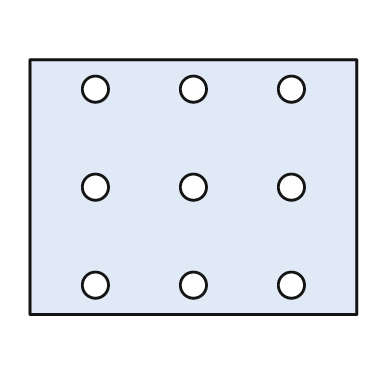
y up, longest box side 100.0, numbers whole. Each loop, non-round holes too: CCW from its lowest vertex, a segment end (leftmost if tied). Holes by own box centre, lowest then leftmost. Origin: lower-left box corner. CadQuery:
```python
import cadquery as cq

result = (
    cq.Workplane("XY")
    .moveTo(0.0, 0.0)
    .lineTo(100.0, 0.0)
    .lineTo(100.0, 78.0)
    .lineTo(0.0, 78.0)
    .close()
    .moveTo(20.0, 9.0)
    .circle(4.0)
    .moveTo(50.0, 9.0)
    .circle(4.0)
    .moveTo(80.0, 9.0)
    .circle(4.0)
    .moveTo(20.0, 39.0)
    .circle(4.0)
    .moveTo(50.0, 39.0)
    .circle(4.0)
    .moveTo(80.0, 39.0)
    .circle(4.0)
    .moveTo(20.0, 69.0)
    .circle(4.0)
    .moveTo(50.0, 69.0)
    .circle(4.0)
    .moveTo(80.0, 69.0)
    .circle(4.0)
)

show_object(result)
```